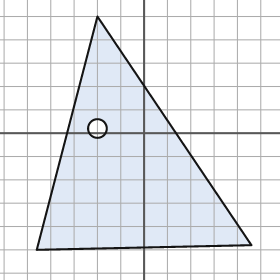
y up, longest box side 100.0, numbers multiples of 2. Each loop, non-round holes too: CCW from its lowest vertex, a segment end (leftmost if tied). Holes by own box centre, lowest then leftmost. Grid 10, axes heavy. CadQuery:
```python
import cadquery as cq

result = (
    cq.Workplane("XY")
    .moveTo(-46.0, -50.0)
    .lineTo(46.0, -48.0)
    .lineTo(-20.0, 50.0)
    .close()
    .moveTo(-20.0, 2.0)
    .circle(4.0)
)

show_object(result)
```